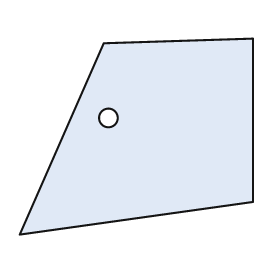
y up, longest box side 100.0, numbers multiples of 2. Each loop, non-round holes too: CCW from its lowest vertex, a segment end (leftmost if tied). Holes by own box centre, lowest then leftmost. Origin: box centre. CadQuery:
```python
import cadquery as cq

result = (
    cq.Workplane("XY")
    .moveTo(-50.0, -42.0)
    .lineTo(50.0, -28.0)
    .lineTo(50.0, 42.0)
    .lineTo(-14.0, 40.0)
    .close()
    .moveTo(-12.0, 8.0)
    .circle(4.0)
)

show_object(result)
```